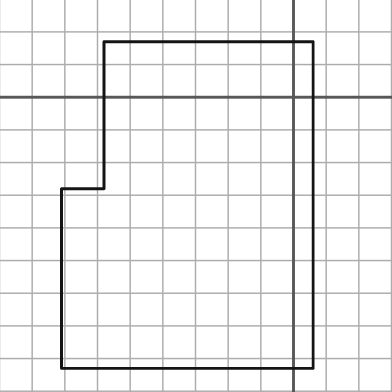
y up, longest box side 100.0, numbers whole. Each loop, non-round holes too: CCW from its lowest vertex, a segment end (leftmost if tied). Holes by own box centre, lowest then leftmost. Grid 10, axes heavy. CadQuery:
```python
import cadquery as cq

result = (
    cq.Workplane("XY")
    .moveTo(-71.0, -83.0)
    .lineTo(6.0, -83.0)
    .lineTo(6.0, 17.0)
    .lineTo(-58.0, 17.0)
    .lineTo(-58.0, -28.0)
    .lineTo(-71.0, -28.0)
    .close()
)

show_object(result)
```